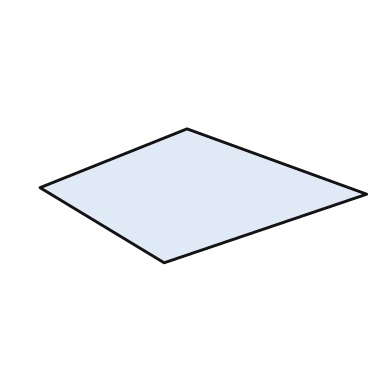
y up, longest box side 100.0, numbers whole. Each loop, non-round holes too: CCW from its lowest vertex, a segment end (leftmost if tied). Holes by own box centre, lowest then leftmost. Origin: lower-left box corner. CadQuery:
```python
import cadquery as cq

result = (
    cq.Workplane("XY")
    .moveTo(38.0, 0.0)
    .lineTo(100.0, 21.0)
    .lineTo(45.0, 41.0)
    .lineTo(0.0, 23.0)
    .close()
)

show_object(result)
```